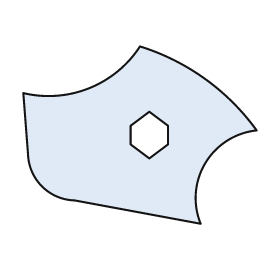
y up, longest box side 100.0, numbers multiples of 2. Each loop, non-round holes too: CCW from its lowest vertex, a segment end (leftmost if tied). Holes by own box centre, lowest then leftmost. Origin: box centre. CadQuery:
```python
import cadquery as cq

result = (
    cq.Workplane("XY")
    .moveTo(26.0, -38.0)
    .threePointArc((28.0, -12.0), (50.0, 2.0))
    .threePointArc((28.0, 24.0), (0.0, 38.0))
    .threePointArc((-22.0, 20.0), (-50.0, 18.0))
    .lineTo(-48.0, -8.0)
    .threePointArc((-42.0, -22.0), (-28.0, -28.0))
    .close()
    .moveTo(4.0, -10.0)
    .lineTo(12.0, -4.0)
    .lineTo(12.0, 4.0)
    .lineTo(4.0, 10.0)
    .lineTo(-4.0, 4.0)
    .lineTo(-4.0, -4.0)
    .close()
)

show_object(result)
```